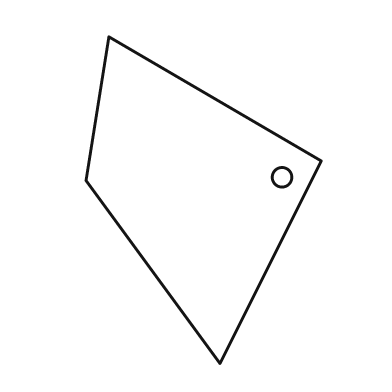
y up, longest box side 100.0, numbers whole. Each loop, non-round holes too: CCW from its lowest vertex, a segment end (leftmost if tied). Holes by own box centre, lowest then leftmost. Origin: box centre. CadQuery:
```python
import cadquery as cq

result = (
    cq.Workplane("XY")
    .moveTo(5.0, -50.0)
    .lineTo(36.0, 12.0)
    .lineTo(-29.0, 50.0)
    .lineTo(-36.0, 6.0)
    .close()
    .moveTo(24.0, 7.0)
    .circle(3.0)
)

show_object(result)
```